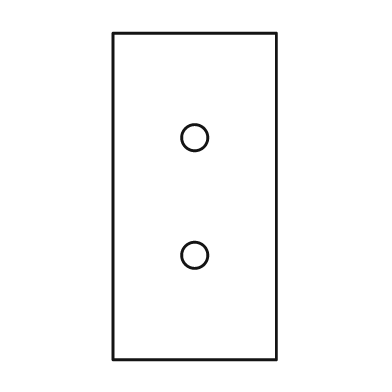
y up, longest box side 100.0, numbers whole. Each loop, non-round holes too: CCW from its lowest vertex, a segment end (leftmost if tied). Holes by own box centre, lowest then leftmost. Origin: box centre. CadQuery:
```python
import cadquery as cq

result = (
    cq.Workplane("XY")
    .moveTo(-25.0, -50.0)
    .lineTo(25.0, -50.0)
    .lineTo(25.0, 50.0)
    .lineTo(-25.0, 50.0)
    .close()
    .moveTo(0.0, -18.0)
    .circle(4.0)
    .moveTo(0.0, 18.0)
    .circle(4.0)
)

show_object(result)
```